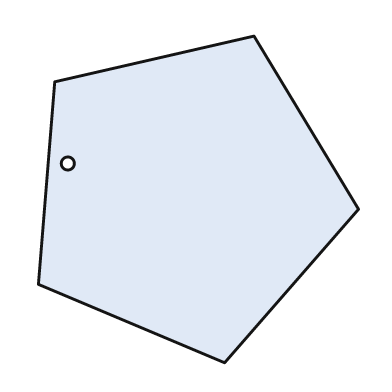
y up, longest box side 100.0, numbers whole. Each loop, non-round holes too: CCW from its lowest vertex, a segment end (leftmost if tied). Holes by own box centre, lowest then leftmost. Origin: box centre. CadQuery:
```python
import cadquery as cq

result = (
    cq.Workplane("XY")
    .moveTo(8.0, -50.0)
    .lineTo(49.0, -3.0)
    .lineTo(17.0, 50.0)
    .lineTo(-44.0, 36.0)
    .lineTo(-49.0, -26.0)
    .close()
    .moveTo(-40.0, 11.0)
    .circle(2.0)
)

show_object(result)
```